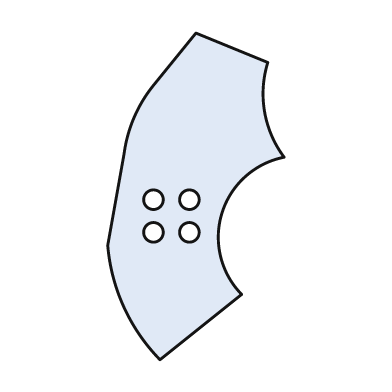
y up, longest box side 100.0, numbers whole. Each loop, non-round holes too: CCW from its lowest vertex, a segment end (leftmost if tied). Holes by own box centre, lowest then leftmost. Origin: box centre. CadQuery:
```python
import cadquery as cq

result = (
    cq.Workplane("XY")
    .moveTo(-11.0, -50.0)
    .lineTo(14.0, -30.0)
    .threePointArc((8.0, -5.0), (27.0, 12.0))
    .threePointArc((21.0, 26.0), (22.0, 41.0))
    .lineTo(0.0, 50.0)
    .lineTo(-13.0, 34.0)
    .threePointArc((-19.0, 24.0), (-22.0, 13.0))
    .lineTo(-27.0, -15.0)
    .threePointArc((-22.0, -34.0), (-11.0, -50.0))
    .close()
    .moveTo(-13.0, -11.0)
    .circle(3.0)
    .moveTo(-2.0, -11.0)
    .circle(3.0)
    .moveTo(-13.0, -1.0)
    .circle(3.0)
    .moveTo(-2.0, -1.0)
    .circle(3.0)
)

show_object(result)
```